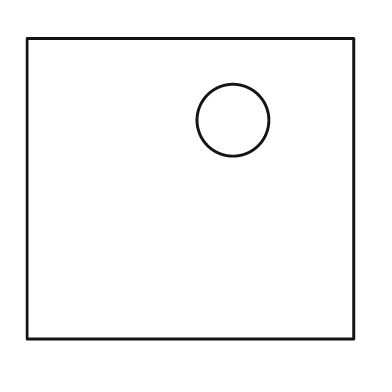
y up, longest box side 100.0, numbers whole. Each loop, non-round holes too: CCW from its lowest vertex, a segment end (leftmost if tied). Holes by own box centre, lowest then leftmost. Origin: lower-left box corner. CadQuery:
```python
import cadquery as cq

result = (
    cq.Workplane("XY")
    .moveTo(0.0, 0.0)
    .lineTo(100.0, 0.0)
    .lineTo(100.0, 92.0)
    .lineTo(0.0, 92.0)
    .close()
    .moveTo(63.0, 67.0)
    .circle(11.0)
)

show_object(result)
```